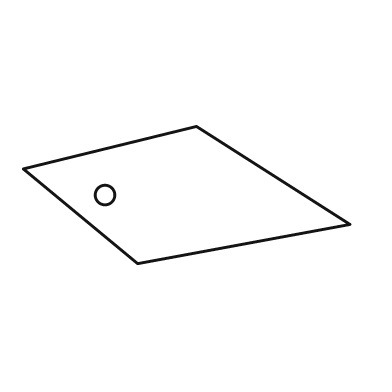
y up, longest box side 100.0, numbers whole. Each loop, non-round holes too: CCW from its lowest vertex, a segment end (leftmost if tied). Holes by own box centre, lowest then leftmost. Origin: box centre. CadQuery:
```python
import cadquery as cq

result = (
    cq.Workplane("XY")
    .moveTo(-15.0, -21.0)
    .lineTo(50.0, -9.0)
    .lineTo(3.0, 21.0)
    .lineTo(-50.0, 8.0)
    .close()
    .moveTo(-25.0, 0.0)
    .circle(3.0)
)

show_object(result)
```